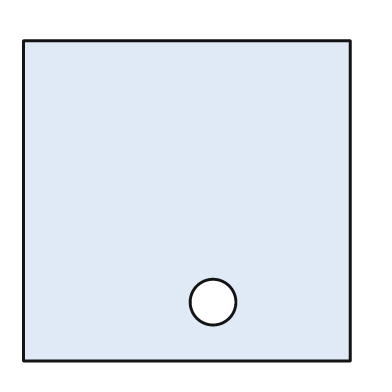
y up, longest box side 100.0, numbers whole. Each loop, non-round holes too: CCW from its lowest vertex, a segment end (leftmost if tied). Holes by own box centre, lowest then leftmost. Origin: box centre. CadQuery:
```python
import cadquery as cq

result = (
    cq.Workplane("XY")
    .moveTo(-50.0, -49.0)
    .lineTo(50.0, -49.0)
    .lineTo(50.0, 49.0)
    .lineTo(-50.0, 49.0)
    .close()
    .moveTo(8.0, -31.0)
    .circle(7.0)
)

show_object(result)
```